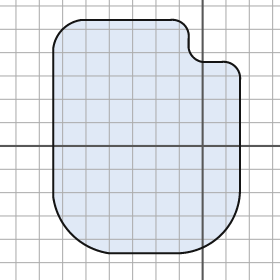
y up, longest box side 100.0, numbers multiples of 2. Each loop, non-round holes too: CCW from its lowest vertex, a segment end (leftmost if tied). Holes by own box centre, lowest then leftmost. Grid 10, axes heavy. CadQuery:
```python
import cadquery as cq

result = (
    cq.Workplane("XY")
    .moveTo(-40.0, -46.0)
    .lineTo(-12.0, -46.0)
    .threePointArc((8.0, -38.0), (16.0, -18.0))
    .lineTo(16.0, 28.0)
    .threePointArc((14.0, 34.0), (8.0, 36.0))
    .lineTo(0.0, 36.0)
    .threePointArc((-4.0, 38.0), (-6.0, 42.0))
    .lineTo(-6.0, 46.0)
    .threePointArc((-8.0, 52.0), (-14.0, 54.0))
    .lineTo(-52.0, 54.0)
    .threePointArc((-60.0, 50.0), (-64.0, 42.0))
    .lineTo(-64.0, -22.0)
    .threePointArc((-56.0, -38.0), (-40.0, -46.0))
    .close()
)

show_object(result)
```